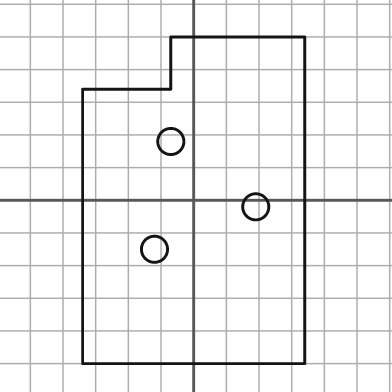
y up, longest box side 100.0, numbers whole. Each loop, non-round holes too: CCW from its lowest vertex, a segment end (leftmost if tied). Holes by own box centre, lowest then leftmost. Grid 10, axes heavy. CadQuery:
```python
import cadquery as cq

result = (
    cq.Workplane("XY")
    .moveTo(-34.0, -50.0)
    .lineTo(34.0, -50.0)
    .lineTo(34.0, 50.0)
    .lineTo(-7.0, 50.0)
    .lineTo(-7.0, 34.0)
    .lineTo(-34.0, 34.0)
    .close()
    .moveTo(-12.0, -15.0)
    .circle(4.0)
    .moveTo(19.0, -2.0)
    .circle(4.0)
    .moveTo(-7.0, 18.0)
    .circle(4.0)
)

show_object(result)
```